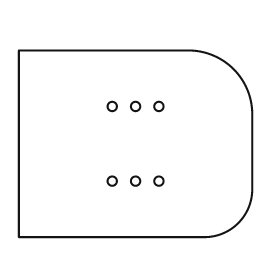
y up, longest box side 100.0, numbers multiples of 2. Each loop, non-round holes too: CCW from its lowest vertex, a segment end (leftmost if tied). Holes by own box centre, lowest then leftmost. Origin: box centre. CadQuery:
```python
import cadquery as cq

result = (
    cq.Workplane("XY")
    .moveTo(-50.0, -40.0)
    .lineTo(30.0, -40.0)
    .threePointArc((44.0, -34.0), (50.0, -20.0))
    .lineTo(50.0, 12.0)
    .threePointArc((42.0, 32.0), (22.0, 40.0))
    .lineTo(-50.0, 40.0)
    .close()
    .moveTo(-10.0, -16.0)
    .circle(2.0)
    .moveTo(0.0, -16.0)
    .circle(2.0)
    .moveTo(10.0, -16.0)
    .circle(2.0)
    .moveTo(-10.0, 16.0)
    .circle(2.0)
    .moveTo(0.0, 16.0)
    .circle(2.0)
    .moveTo(10.0, 16.0)
    .circle(2.0)
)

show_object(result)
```